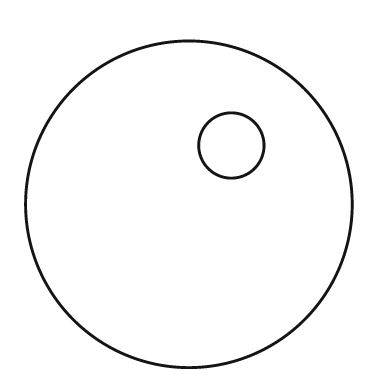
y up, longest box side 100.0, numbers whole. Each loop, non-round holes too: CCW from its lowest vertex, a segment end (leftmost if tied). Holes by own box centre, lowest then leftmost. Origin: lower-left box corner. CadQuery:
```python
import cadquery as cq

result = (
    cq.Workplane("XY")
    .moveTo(50.0, 50.0)
    .circle(50.0)
    .moveTo(63.0, 68.0)
    .circle(10.0)
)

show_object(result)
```